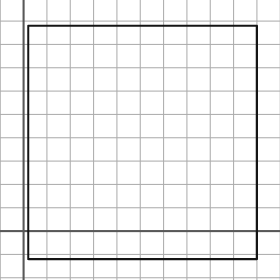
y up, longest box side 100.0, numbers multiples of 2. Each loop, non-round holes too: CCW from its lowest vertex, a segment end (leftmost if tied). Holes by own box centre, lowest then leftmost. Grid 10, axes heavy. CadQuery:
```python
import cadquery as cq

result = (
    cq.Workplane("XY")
    .moveTo(2.0, -12.0)
    .lineTo(100.0, -12.0)
    .lineTo(100.0, 88.0)
    .lineTo(2.0, 88.0)
    .close()
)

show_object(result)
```